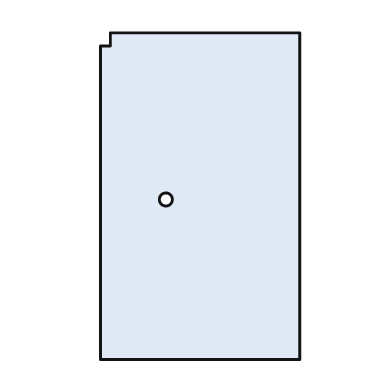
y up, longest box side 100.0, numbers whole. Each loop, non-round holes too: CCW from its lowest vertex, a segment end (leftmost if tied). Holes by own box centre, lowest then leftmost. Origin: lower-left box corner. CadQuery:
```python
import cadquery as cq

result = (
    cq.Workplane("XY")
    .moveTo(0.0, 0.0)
    .lineTo(61.0, 0.0)
    .lineTo(61.0, 100.0)
    .lineTo(3.0, 100.0)
    .lineTo(3.0, 96.0)
    .lineTo(0.0, 96.0)
    .close()
    .moveTo(20.0, 49.0)
    .circle(2.0)
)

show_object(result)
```